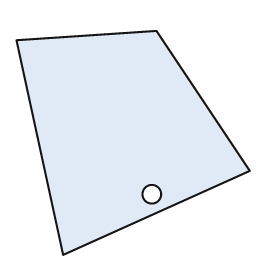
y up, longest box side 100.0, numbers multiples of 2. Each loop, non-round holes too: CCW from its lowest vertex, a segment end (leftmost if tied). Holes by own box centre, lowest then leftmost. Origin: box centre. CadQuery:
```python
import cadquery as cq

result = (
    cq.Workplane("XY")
    .moveTo(-30.0, -48.0)
    .lineTo(50.0, -12.0)
    .lineTo(10.0, 48.0)
    .lineTo(-50.0, 44.0)
    .close()
    .moveTo(8.0, -22.0)
    .circle(4.0)
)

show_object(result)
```